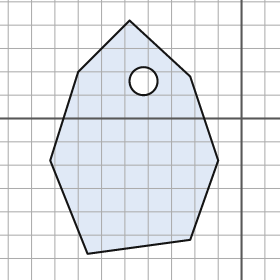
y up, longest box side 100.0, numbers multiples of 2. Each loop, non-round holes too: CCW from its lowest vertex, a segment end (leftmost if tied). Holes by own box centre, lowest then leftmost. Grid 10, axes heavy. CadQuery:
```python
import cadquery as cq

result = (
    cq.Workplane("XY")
    .moveTo(-66.0, -58.0)
    .lineTo(-22.0, -52.0)
    .lineTo(-10.0, -18.0)
    .lineTo(-22.0, 18.0)
    .lineTo(-48.0, 42.0)
    .lineTo(-70.0, 20.0)
    .lineTo(-82.0, -18.0)
    .close()
    .moveTo(-42.0, 16.0)
    .circle(6.0)
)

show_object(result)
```